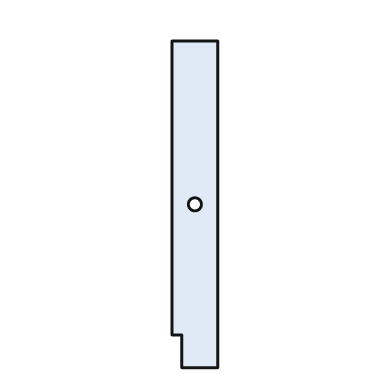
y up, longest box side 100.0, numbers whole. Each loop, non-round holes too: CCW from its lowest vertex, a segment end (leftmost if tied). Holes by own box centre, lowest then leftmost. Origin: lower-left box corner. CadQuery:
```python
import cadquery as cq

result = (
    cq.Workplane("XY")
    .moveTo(3.0, 0.0)
    .lineTo(14.0, 0.0)
    .lineTo(14.0, 100.0)
    .lineTo(0.0, 100.0)
    .lineTo(0.0, 10.0)
    .lineTo(3.0, 10.0)
    .close()
    .moveTo(7.0, 50.0)
    .circle(2.0)
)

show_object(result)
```